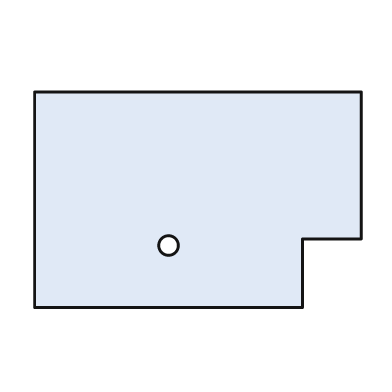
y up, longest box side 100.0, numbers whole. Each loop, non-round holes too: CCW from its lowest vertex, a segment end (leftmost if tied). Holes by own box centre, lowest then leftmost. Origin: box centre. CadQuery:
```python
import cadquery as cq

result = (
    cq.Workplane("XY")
    .moveTo(-50.0, -33.0)
    .lineTo(32.0, -33.0)
    .lineTo(32.0, -12.0)
    .lineTo(50.0, -12.0)
    .lineTo(50.0, 33.0)
    .lineTo(-50.0, 33.0)
    .close()
    .moveTo(-9.0, -14.0)
    .circle(3.0)
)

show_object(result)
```